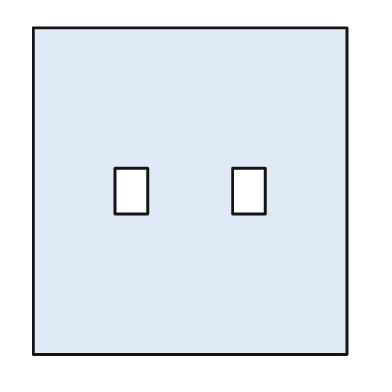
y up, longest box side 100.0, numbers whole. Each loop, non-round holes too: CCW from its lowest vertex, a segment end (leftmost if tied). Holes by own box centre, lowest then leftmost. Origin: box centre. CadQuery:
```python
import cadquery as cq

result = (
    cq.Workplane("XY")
    .moveTo(-48.0, -50.0)
    .lineTo(48.0, -50.0)
    .lineTo(48.0, 50.0)
    .lineTo(-48.0, 50.0)
    .close()
    .moveTo(-23.0, -7.0)
    .lineTo(-13.0, -7.0)
    .lineTo(-13.0, 7.0)
    .lineTo(-23.0, 7.0)
    .close()
    .moveTo(13.0, -7.0)
    .lineTo(23.0, -7.0)
    .lineTo(23.0, 7.0)
    .lineTo(13.0, 7.0)
    .close()
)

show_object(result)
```